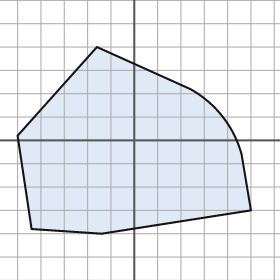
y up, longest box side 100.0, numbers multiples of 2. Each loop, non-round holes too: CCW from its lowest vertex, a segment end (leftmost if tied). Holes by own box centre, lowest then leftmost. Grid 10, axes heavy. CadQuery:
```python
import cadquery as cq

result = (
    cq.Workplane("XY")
    .moveTo(-14.0, -40.0)
    .lineTo(50.0, -30.0)
    .lineTo(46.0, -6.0)
    .threePointArc((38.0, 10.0), (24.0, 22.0))
    .lineTo(-16.0, 40.0)
    .lineTo(-50.0, 2.0)
    .lineTo(-44.0, -38.0)
    .close()
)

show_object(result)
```